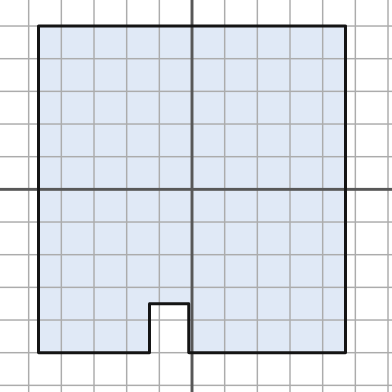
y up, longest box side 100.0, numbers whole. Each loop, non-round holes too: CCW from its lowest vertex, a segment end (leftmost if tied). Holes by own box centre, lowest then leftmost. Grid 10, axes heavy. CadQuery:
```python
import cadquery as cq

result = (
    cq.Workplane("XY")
    .moveTo(-47.0, -50.0)
    .lineTo(-13.0, -50.0)
    .lineTo(-13.0, -35.0)
    .lineTo(-1.0, -35.0)
    .lineTo(-1.0, -50.0)
    .lineTo(47.0, -50.0)
    .lineTo(47.0, 50.0)
    .lineTo(-47.0, 50.0)
    .close()
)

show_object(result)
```